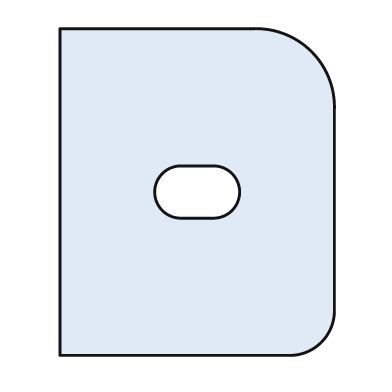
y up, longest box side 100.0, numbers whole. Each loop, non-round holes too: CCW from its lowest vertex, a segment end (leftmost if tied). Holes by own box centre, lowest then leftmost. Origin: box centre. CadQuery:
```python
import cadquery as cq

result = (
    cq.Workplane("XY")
    .moveTo(-42.0, -50.0)
    .lineTo(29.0, -50.0)
    .threePointArc((38.0, -46.0), (42.0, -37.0))
    .lineTo(42.0, 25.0)
    .threePointArc((35.0, 43.0), (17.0, 50.0))
    .lineTo(-42.0, 50.0)
    .close()
    .moveTo(-5.0, -8.0)
    .lineTo(5.0, -8.0)
    .threePointArc((13.0, 0.0), (5.0, 8.0))
    .lineTo(-5.0, 8.0)
    .threePointArc((-13.0, 0.0), (-5.0, -8.0))
    .close()
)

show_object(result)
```